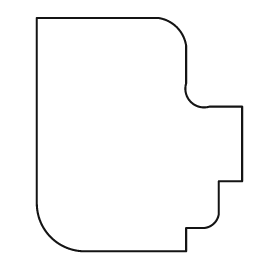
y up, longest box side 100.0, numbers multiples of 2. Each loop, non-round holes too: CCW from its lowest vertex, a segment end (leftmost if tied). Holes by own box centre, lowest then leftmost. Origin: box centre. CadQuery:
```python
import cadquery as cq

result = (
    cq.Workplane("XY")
    .moveTo(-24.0, -50.0)
    .lineTo(20.0, -50.0)
    .lineTo(20.0, -40.0)
    .lineTo(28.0, -40.0)
    .threePointArc((32.0, -38.0), (34.0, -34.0))
    .lineTo(34.0, -20.0)
    .lineTo(44.0, -20.0)
    .lineTo(44.0, 12.0)
    .lineTo(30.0, 12.0)
    .threePointArc((22.0, 14.0), (20.0, 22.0))
    .lineTo(20.0, 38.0)
    .threePointArc((16.0, 46.0), (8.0, 50.0))
    .lineTo(-44.0, 50.0)
    .lineTo(-44.0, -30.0)
    .threePointArc((-38.0, -44.0), (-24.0, -50.0))
    .close()
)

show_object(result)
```